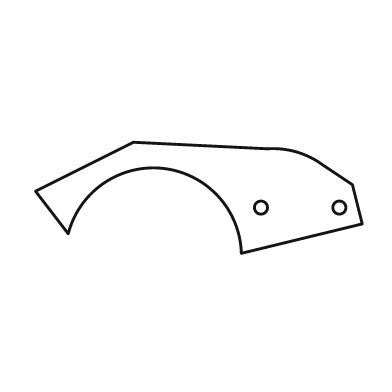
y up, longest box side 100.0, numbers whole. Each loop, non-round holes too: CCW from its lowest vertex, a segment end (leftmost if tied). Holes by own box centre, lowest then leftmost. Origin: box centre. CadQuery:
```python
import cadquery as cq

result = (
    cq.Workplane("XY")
    .moveTo(13.0, -17.0)
    .lineTo(50.0, -8.0)
    .lineTo(47.0, 4.0)
    .lineTo(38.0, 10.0)
    .threePointArc((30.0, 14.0), (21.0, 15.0))
    .lineTo(-20.0, 17.0)
    .lineTo(-50.0, 2.0)
    .lineTo(-40.0, -11.0)
    .threePointArc((-11.0, 9.0), (13.0, -17.0))
    .close()
    .moveTo(19.0, -3.0)
    .circle(2.0)
    .moveTo(43.0, -3.0)
    .circle(2.0)
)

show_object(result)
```